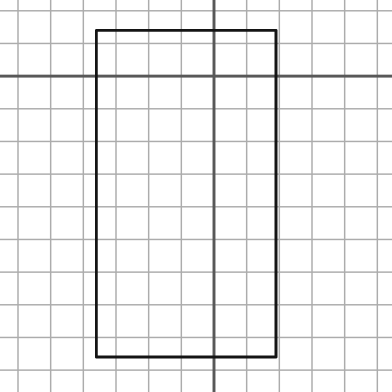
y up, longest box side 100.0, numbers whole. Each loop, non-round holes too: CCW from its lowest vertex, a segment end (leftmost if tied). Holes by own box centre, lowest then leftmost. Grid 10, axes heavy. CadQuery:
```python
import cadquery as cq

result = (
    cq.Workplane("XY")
    .moveTo(-36.0, -86.0)
    .lineTo(19.0, -86.0)
    .lineTo(19.0, 14.0)
    .lineTo(-36.0, 14.0)
    .close()
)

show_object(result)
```